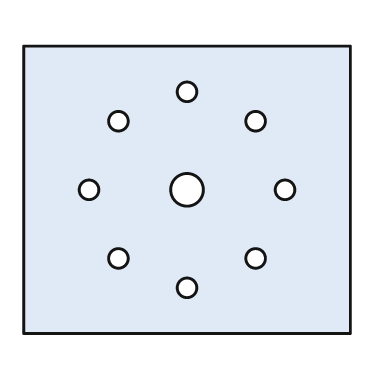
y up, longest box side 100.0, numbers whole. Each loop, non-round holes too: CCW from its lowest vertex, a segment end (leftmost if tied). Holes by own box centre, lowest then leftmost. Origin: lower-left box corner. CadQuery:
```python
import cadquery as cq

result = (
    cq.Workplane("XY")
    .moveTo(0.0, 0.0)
    .lineTo(100.0, 0.0)
    .lineTo(100.0, 88.0)
    .lineTo(0.0, 88.0)
    .close()
    .moveTo(50.0, 14.0)
    .circle(3.0)
    .moveTo(29.0, 23.0)
    .circle(3.0)
    .moveTo(71.0, 23.0)
    .circle(3.0)
    .moveTo(20.0, 44.0)
    .circle(3.0)
    .moveTo(50.0, 44.0)
    .circle(5.0)
    .moveTo(80.0, 44.0)
    .circle(3.0)
    .moveTo(29.0, 65.0)
    .circle(3.0)
    .moveTo(71.0, 65.0)
    .circle(3.0)
    .moveTo(50.0, 74.0)
    .circle(3.0)
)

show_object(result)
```